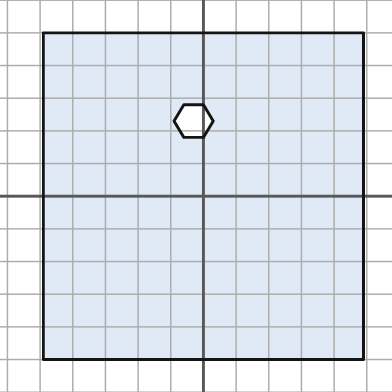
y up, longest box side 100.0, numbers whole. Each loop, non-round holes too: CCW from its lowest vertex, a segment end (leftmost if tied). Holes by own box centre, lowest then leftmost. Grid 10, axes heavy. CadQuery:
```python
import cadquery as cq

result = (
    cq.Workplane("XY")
    .moveTo(-49.0, -50.0)
    .lineTo(49.0, -50.0)
    .lineTo(49.0, 50.0)
    .lineTo(-49.0, 50.0)
    .close()
    .moveTo(-6.0, 18.0)
    .lineTo(0.0, 18.0)
    .lineTo(3.0, 23.0)
    .lineTo(0.0, 28.0)
    .lineTo(-6.0, 28.0)
    .lineTo(-9.0, 23.0)
    .close()
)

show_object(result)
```